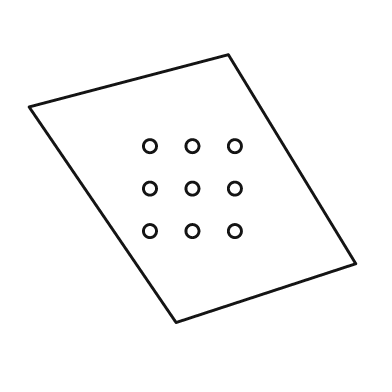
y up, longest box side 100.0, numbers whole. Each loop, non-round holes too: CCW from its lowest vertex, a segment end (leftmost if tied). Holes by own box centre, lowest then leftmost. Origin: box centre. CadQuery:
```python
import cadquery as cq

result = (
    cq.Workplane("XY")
    .moveTo(-5.0, -41.0)
    .lineTo(50.0, -23.0)
    .lineTo(11.0, 41.0)
    .lineTo(-50.0, 25.0)
    .close()
    .moveTo(-13.0, -13.0)
    .circle(2.0)
    .moveTo(0.0, -13.0)
    .circle(2.0)
    .moveTo(13.0, -13.0)
    .circle(2.0)
    .moveTo(-13.0, 0.0)
    .circle(2.0)
    .moveTo(0.0, 0.0)
    .circle(2.0)
    .moveTo(13.0, 0.0)
    .circle(2.0)
    .moveTo(-13.0, 13.0)
    .circle(2.0)
    .moveTo(0.0, 13.0)
    .circle(2.0)
    .moveTo(13.0, 13.0)
    .circle(2.0)
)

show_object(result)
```